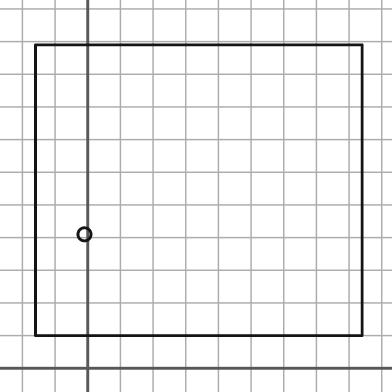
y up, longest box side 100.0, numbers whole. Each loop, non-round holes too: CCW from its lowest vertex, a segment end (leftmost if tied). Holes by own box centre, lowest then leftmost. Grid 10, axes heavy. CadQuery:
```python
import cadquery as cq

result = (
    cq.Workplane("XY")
    .moveTo(-16.0, 10.0)
    .lineTo(84.0, 10.0)
    .lineTo(84.0, 99.0)
    .lineTo(-16.0, 99.0)
    .close()
    .moveTo(-1.0, 41.0)
    .circle(2.0)
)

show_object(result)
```